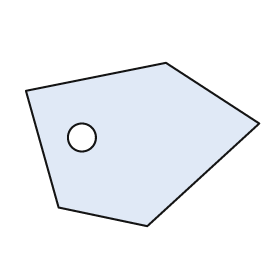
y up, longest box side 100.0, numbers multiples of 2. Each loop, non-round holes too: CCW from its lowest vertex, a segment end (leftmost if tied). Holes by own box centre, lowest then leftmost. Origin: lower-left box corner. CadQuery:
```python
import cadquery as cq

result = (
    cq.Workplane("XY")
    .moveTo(52.0, 0.0)
    .lineTo(100.0, 44.0)
    .lineTo(60.0, 70.0)
    .lineTo(0.0, 58.0)
    .lineTo(14.0, 8.0)
    .close()
    .moveTo(24.0, 38.0)
    .circle(6.0)
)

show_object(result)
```